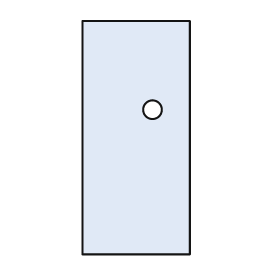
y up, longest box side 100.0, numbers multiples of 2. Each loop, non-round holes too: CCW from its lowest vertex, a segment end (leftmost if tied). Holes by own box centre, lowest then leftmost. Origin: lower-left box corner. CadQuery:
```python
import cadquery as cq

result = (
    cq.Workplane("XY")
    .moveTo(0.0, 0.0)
    .lineTo(46.0, 0.0)
    .lineTo(46.0, 100.0)
    .lineTo(0.0, 100.0)
    .close()
    .moveTo(30.0, 62.0)
    .circle(4.0)
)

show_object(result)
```